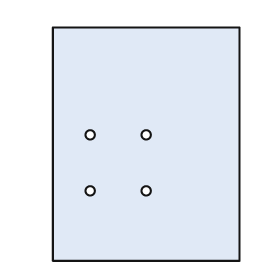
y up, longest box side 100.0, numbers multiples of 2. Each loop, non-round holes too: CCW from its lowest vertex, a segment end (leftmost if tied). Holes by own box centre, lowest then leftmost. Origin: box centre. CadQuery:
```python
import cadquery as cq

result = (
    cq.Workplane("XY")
    .moveTo(-40.0, -50.0)
    .lineTo(40.0, -50.0)
    .lineTo(40.0, 50.0)
    .lineTo(-40.0, 50.0)
    .close()
    .moveTo(-24.0, -20.0)
    .circle(2.0)
    .moveTo(0.0, -20.0)
    .circle(2.0)
    .moveTo(-24.0, 4.0)
    .circle(2.0)
    .moveTo(0.0, 4.0)
    .circle(2.0)
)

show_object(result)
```